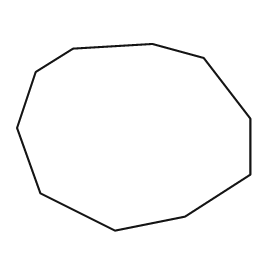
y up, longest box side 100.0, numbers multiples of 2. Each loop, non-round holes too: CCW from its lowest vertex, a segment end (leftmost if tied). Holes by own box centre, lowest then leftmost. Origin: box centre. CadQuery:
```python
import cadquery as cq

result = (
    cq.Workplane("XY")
    .moveTo(-8.0, -40.0)
    .lineTo(22.0, -34.0)
    .lineTo(50.0, -16.0)
    .lineTo(50.0, 8.0)
    .lineTo(30.0, 34.0)
    .lineTo(8.0, 40.0)
    .lineTo(-26.0, 38.0)
    .lineTo(-42.0, 28.0)
    .lineTo(-50.0, 4.0)
    .lineTo(-40.0, -24.0)
    .close()
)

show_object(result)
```